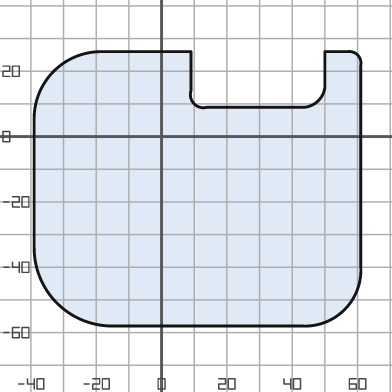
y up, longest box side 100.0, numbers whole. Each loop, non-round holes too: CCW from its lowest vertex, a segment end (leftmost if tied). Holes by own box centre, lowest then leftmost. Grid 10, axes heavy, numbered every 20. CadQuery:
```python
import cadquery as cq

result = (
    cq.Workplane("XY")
    .moveTo(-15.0, -58.0)
    .lineTo(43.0, -58.0)
    .threePointArc((56.0, -53.0), (61.0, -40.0))
    .lineTo(61.0, 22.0)
    .threePointArc((60.0, 25.0), (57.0, 26.0))
    .lineTo(50.0, 26.0)
    .lineTo(50.0, 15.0)
    .threePointArc((48.0, 11.0), (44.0, 9.0))
    .lineTo(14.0, 9.0)
    .threePointArc((10.0, 10.0), (9.0, 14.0))
    .lineTo(9.0, 26.0)
    .lineTo(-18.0, 26.0)
    .threePointArc((-33.0, 20.0), (-39.0, 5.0))
    .lineTo(-39.0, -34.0)
    .threePointArc((-32.0, -51.0), (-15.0, -58.0))
    .close()
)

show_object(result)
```